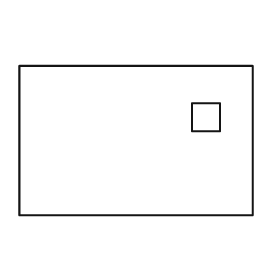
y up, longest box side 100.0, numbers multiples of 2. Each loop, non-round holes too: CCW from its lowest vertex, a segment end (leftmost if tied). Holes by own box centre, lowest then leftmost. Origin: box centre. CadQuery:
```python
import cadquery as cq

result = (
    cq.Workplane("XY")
    .moveTo(-50.0, -32.0)
    .lineTo(50.0, -32.0)
    .lineTo(50.0, 32.0)
    .lineTo(-50.0, 32.0)
    .close()
    .moveTo(24.0, 4.0)
    .lineTo(36.0, 4.0)
    .lineTo(36.0, 16.0)
    .lineTo(24.0, 16.0)
    .close()
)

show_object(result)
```